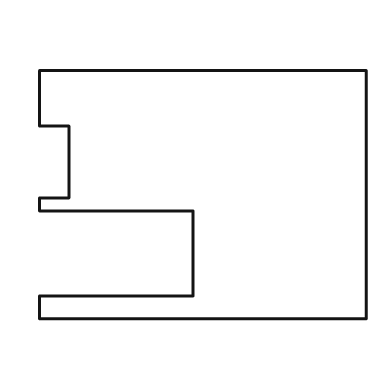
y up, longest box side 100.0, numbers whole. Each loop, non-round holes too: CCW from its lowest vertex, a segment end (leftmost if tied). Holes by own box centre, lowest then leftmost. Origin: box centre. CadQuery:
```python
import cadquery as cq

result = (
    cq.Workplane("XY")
    .moveTo(-50.0, -38.0)
    .lineTo(50.0, -38.0)
    .lineTo(50.0, 38.0)
    .lineTo(-50.0, 38.0)
    .lineTo(-50.0, 21.0)
    .lineTo(-41.0, 21.0)
    .lineTo(-41.0, -1.0)
    .lineTo(-50.0, -1.0)
    .lineTo(-50.0, -5.0)
    .lineTo(-3.0, -5.0)
    .lineTo(-3.0, -31.0)
    .lineTo(-50.0, -31.0)
    .close()
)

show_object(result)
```